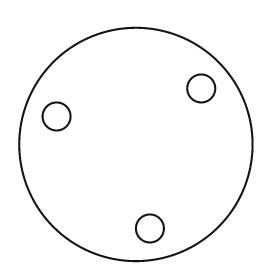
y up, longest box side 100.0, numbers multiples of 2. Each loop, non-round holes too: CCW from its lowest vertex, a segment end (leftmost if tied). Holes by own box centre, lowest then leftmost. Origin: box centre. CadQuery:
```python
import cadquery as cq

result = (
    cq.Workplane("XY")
    .moveTo(0.0, 0.0)
    .circle(50.0)
    .moveTo(6.0, -36.0)
    .circle(6.0)
    .moveTo(-34.0, 12.0)
    .circle(6.0)
    .moveTo(28.0, 24.0)
    .circle(6.0)
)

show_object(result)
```